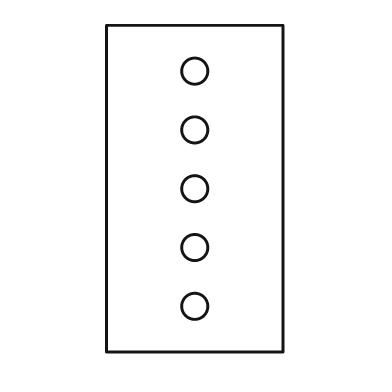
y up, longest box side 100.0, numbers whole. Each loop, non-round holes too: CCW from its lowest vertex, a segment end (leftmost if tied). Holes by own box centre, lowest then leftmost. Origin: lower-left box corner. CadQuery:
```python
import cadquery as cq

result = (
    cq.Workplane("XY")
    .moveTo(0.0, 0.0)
    .lineTo(54.0, 0.0)
    .lineTo(54.0, 100.0)
    .lineTo(0.0, 100.0)
    .close()
    .moveTo(27.0, 14.0)
    .circle(4.0)
    .moveTo(27.0, 32.0)
    .circle(4.0)
    .moveTo(27.0, 50.0)
    .circle(4.0)
    .moveTo(27.0, 68.0)
    .circle(4.0)
    .moveTo(27.0, 86.0)
    .circle(4.0)
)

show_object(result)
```